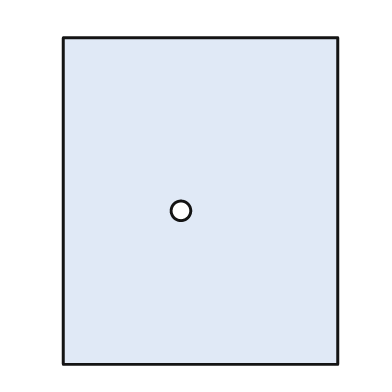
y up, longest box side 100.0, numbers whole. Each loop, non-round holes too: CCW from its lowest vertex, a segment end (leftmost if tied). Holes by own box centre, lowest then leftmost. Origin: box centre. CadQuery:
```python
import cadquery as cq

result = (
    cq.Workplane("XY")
    .moveTo(-42.0, -50.0)
    .lineTo(42.0, -50.0)
    .lineTo(42.0, 50.0)
    .lineTo(-42.0, 50.0)
    .close()
    .moveTo(-6.0, -3.0)
    .circle(3.0)
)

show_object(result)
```